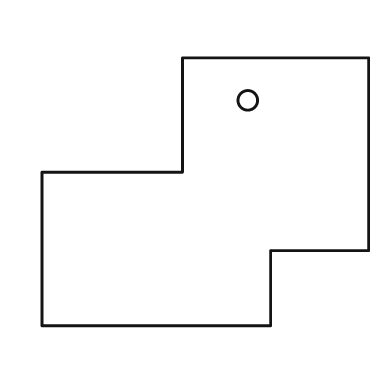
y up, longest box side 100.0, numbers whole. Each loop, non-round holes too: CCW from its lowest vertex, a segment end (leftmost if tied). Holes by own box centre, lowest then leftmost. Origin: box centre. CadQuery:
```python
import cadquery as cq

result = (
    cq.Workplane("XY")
    .moveTo(-50.0, -41.0)
    .lineTo(20.0, -41.0)
    .lineTo(20.0, -18.0)
    .lineTo(50.0, -18.0)
    .lineTo(50.0, 41.0)
    .lineTo(-7.0, 41.0)
    .lineTo(-7.0, 6.0)
    .lineTo(-50.0, 6.0)
    .close()
    .moveTo(13.0, 28.0)
    .circle(3.0)
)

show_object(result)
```